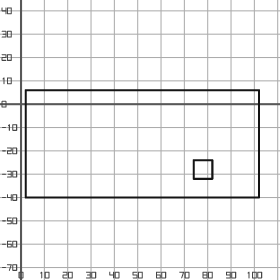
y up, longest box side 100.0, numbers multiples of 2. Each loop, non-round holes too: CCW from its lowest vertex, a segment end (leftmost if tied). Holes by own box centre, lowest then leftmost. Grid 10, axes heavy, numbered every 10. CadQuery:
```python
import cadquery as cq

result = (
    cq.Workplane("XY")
    .moveTo(2.0, -40.0)
    .lineTo(102.0, -40.0)
    .lineTo(102.0, 6.0)
    .lineTo(2.0, 6.0)
    .close()
    .moveTo(74.0, -32.0)
    .lineTo(82.0, -32.0)
    .lineTo(82.0, -24.0)
    .lineTo(74.0, -24.0)
    .close()
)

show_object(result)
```